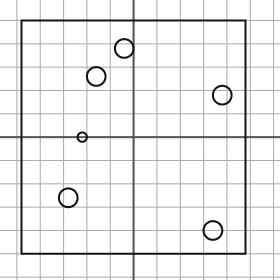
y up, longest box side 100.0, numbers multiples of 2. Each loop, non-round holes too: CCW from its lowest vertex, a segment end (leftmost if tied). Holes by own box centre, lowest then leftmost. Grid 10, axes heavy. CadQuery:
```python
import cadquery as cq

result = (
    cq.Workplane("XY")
    .moveTo(-48.0, -50.0)
    .lineTo(48.0, -50.0)
    .lineTo(48.0, 50.0)
    .lineTo(-48.0, 50.0)
    .close()
    .moveTo(34.0, -40.0)
    .circle(4.0)
    .moveTo(-28.0, -26.0)
    .circle(4.0)
    .moveTo(-22.0, 0.0)
    .circle(2.0)
    .moveTo(38.0, 18.0)
    .circle(4.0)
    .moveTo(-16.0, 26.0)
    .circle(4.0)
    .moveTo(-4.0, 38.0)
    .circle(4.0)
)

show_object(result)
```